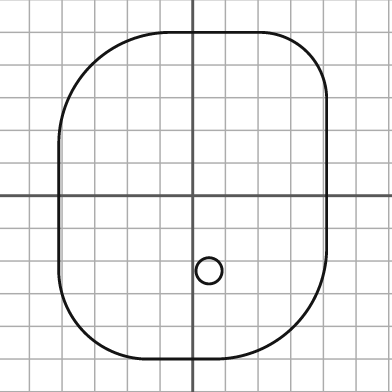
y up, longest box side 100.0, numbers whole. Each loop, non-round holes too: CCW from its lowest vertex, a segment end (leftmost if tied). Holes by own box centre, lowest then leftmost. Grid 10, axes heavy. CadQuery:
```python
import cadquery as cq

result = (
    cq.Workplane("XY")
    .moveTo(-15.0, -50.0)
    .lineTo(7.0, -50.0)
    .threePointArc((31.0, -40.0), (41.0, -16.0))
    .lineTo(41.0, 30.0)
    .threePointArc((35.0, 44.0), (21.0, 50.0))
    .lineTo(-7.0, 50.0)
    .threePointArc((-31.0, 40.0), (-41.0, 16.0))
    .lineTo(-41.0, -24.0)
    .threePointArc((-33.0, -42.0), (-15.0, -50.0))
    .close()
    .moveTo(5.0, -23.0)
    .circle(4.0)
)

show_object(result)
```